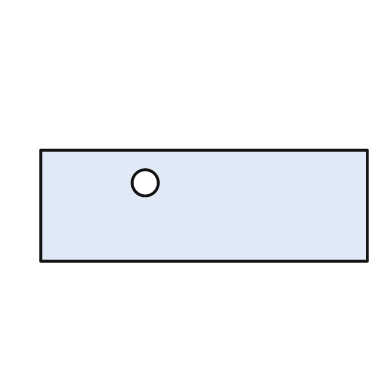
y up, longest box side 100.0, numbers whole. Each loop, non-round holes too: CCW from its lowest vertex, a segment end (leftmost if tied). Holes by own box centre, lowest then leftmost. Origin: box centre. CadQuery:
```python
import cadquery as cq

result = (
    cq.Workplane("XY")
    .moveTo(-50.0, -17.0)
    .lineTo(50.0, -17.0)
    .lineTo(50.0, 17.0)
    .lineTo(-50.0, 17.0)
    .close()
    .moveTo(-18.0, 7.0)
    .circle(4.0)
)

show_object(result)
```